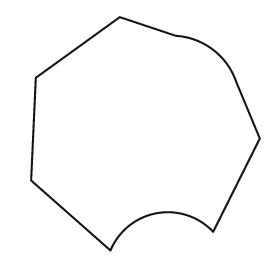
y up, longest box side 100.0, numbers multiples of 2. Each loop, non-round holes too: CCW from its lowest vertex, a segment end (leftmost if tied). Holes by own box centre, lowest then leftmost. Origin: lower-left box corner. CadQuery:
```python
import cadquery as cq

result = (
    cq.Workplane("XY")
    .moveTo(34.0, 0.0)
    .threePointArc((54.0, 16.0), (78.0, 8.0))
    .lineTo(98.0, 48.0)
    .lineTo(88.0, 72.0)
    .threePointArc((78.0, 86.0), (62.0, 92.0))
    .lineTo(38.0, 100.0)
    .lineTo(2.0, 74.0)
    .lineTo(0.0, 30.0)
    .close()
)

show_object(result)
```